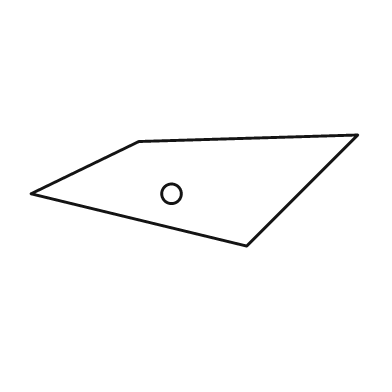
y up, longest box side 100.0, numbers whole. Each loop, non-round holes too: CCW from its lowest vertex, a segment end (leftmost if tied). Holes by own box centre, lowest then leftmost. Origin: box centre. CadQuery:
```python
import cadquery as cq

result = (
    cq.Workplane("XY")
    .moveTo(16.0, -17.0)
    .lineTo(50.0, 17.0)
    .lineTo(-17.0, 15.0)
    .lineTo(-50.0, -1.0)
    .close()
    .moveTo(-7.0, -1.0)
    .circle(3.0)
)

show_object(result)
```